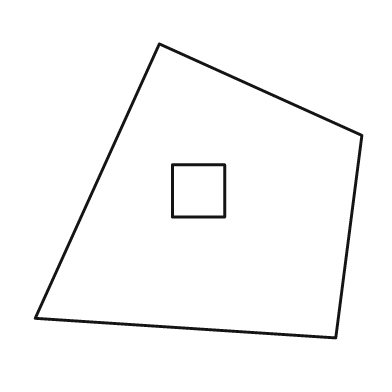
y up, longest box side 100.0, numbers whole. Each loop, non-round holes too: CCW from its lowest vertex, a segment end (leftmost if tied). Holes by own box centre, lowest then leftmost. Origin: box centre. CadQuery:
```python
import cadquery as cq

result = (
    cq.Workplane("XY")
    .moveTo(42.0, -45.0)
    .lineTo(50.0, 17.0)
    .lineTo(-12.0, 45.0)
    .lineTo(-50.0, -39.0)
    .close()
    .moveTo(-8.0, -8.0)
    .lineTo(8.0, -8.0)
    .lineTo(8.0, 8.0)
    .lineTo(-8.0, 8.0)
    .close()
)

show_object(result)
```